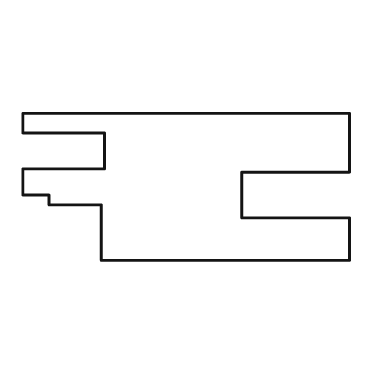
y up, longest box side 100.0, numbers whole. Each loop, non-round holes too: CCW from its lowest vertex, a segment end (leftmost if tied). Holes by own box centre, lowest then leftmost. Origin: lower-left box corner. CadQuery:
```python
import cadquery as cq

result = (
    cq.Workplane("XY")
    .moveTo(24.0, 0.0)
    .lineTo(100.0, 0.0)
    .lineTo(100.0, 13.0)
    .lineTo(67.0, 13.0)
    .lineTo(67.0, 27.0)
    .lineTo(100.0, 27.0)
    .lineTo(100.0, 45.0)
    .lineTo(0.0, 45.0)
    .lineTo(0.0, 39.0)
    .lineTo(25.0, 39.0)
    .lineTo(25.0, 28.0)
    .lineTo(0.0, 28.0)
    .lineTo(0.0, 20.0)
    .lineTo(8.0, 20.0)
    .lineTo(8.0, 17.0)
    .lineTo(24.0, 17.0)
    .close()
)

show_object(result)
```